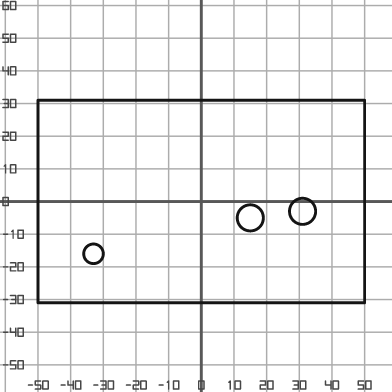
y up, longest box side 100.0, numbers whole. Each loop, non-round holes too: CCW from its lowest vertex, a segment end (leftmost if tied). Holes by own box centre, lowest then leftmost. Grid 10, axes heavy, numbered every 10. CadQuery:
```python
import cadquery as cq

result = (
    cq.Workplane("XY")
    .moveTo(-50.0, -31.0)
    .lineTo(50.0, -31.0)
    .lineTo(50.0, 31.0)
    .lineTo(-50.0, 31.0)
    .close()
    .moveTo(-33.0, -16.0)
    .circle(3.0)
    .moveTo(15.0, -5.0)
    .circle(4.0)
    .moveTo(31.0, -3.0)
    .circle(4.0)
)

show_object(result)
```